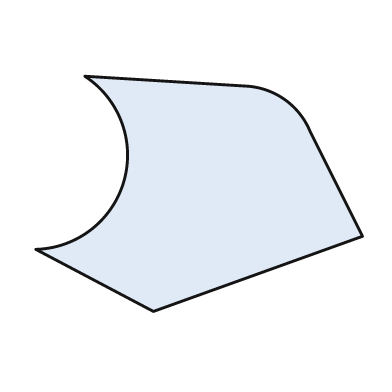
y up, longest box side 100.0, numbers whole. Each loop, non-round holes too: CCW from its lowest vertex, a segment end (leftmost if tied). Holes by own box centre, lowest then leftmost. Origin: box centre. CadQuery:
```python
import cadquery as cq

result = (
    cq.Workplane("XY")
    .moveTo(-14.0, -36.0)
    .lineTo(50.0, -13.0)
    .lineTo(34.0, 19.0)
    .threePointArc((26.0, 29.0), (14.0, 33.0))
    .lineTo(-35.0, 36.0)
    .threePointArc((-23.0, 4.0), (-50.0, -17.0))
    .close()
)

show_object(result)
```